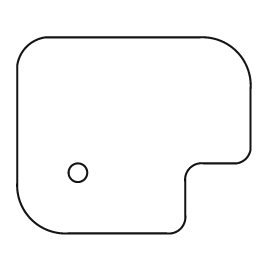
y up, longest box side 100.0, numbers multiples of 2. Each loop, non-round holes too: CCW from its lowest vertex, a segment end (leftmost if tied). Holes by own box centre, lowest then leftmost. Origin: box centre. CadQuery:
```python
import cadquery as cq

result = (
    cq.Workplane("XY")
    .moveTo(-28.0, -42.0)
    .lineTo(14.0, -42.0)
    .threePointArc((20.0, -40.0), (22.0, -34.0))
    .lineTo(22.0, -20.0)
    .threePointArc((24.0, -14.0), (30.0, -12.0))
    .lineTo(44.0, -12.0)
    .threePointArc((48.0, -10.0), (50.0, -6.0))
    .lineTo(50.0, 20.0)
    .threePointArc((44.0, 36.0), (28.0, 42.0))
    .lineTo(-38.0, 42.0)
    .threePointArc((-46.0, 38.0), (-50.0, 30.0))
    .lineTo(-50.0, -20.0)
    .threePointArc((-44.0, -36.0), (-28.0, -42.0))
    .close()
    .moveTo(-24.0, -16.0)
    .circle(4.0)
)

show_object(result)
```